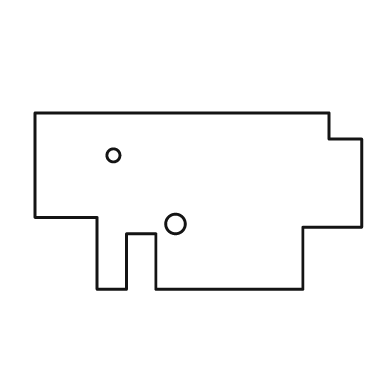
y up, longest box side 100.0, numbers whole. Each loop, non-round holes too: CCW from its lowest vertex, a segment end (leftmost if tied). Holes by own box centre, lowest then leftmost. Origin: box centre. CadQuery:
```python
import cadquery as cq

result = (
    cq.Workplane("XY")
    .moveTo(-31.0, -27.0)
    .lineTo(-22.0, -27.0)
    .lineTo(-22.0, -10.0)
    .lineTo(-13.0, -10.0)
    .lineTo(-13.0, -27.0)
    .lineTo(32.0, -27.0)
    .lineTo(32.0, -8.0)
    .lineTo(50.0, -8.0)
    .lineTo(50.0, 19.0)
    .lineTo(40.0, 19.0)
    .lineTo(40.0, 27.0)
    .lineTo(-50.0, 27.0)
    .lineTo(-50.0, -5.0)
    .lineTo(-31.0, -5.0)
    .close()
    .moveTo(-7.0, -7.0)
    .circle(3.0)
    .moveTo(-26.0, 14.0)
    .circle(2.0)
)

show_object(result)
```